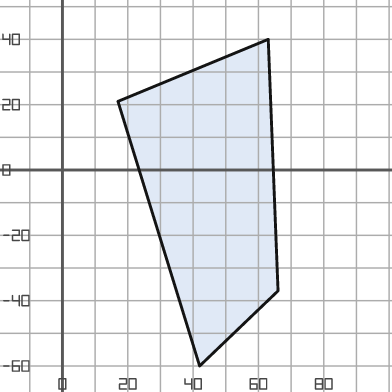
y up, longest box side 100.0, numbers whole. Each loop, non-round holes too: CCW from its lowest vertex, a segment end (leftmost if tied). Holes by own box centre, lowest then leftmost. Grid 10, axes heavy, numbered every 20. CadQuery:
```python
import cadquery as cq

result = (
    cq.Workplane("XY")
    .moveTo(42.0, -60.0)
    .lineTo(66.0, -37.0)
    .lineTo(63.0, 40.0)
    .lineTo(17.0, 21.0)
    .close()
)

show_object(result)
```